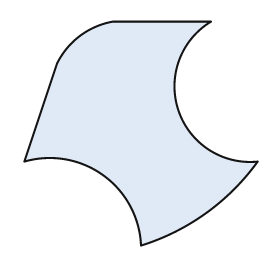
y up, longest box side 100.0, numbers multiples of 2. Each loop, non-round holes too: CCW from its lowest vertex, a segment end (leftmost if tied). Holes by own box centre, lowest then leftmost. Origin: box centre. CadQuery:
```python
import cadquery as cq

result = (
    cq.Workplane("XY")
    .moveTo(0.0, -48.0)
    .threePointArc((28.0, -34.0), (50.0, -12.0))
    .threePointArc((16.0, 10.0), (30.0, 48.0))
    .lineTo(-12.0, 48.0)
    .threePointArc((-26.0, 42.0), (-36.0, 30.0))
    .lineTo(-50.0, -12.0)
    .threePointArc((-16.0, -18.0), (0.0, -48.0))
    .close()
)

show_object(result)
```